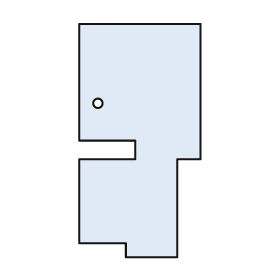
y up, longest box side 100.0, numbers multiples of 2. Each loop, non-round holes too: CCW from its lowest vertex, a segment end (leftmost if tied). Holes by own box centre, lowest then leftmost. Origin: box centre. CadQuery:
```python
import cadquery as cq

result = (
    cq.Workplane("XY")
    .moveTo(-6.0, -50.0)
    .lineTo(16.0, -50.0)
    .lineTo(16.0, -8.0)
    .lineTo(26.0, -8.0)
    .lineTo(26.0, 50.0)
    .lineTo(-26.0, 50.0)
    .lineTo(-26.0, 0.0)
    .lineTo(-2.0, 0.0)
    .lineTo(-2.0, -8.0)
    .lineTo(-26.0, -8.0)
    .lineTo(-26.0, -44.0)
    .lineTo(-6.0, -44.0)
    .close()
    .moveTo(-18.0, 16.0)
    .circle(2.0)
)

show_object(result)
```